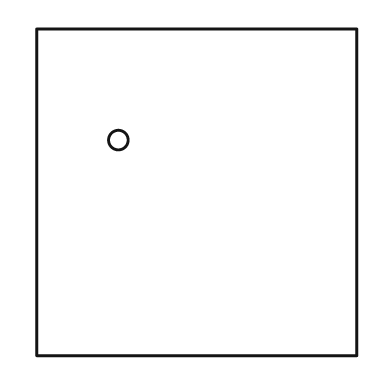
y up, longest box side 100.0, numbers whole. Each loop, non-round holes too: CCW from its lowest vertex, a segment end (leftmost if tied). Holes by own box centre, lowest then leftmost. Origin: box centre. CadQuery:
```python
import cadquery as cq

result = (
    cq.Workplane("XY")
    .moveTo(-49.0, -50.0)
    .lineTo(49.0, -50.0)
    .lineTo(49.0, 50.0)
    .lineTo(-49.0, 50.0)
    .close()
    .moveTo(-24.0, 16.0)
    .circle(3.0)
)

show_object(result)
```